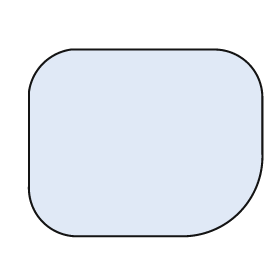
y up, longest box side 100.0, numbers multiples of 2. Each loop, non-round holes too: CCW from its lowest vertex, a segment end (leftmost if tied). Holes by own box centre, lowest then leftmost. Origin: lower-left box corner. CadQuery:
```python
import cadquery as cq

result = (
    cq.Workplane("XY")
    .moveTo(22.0, 0.0)
    .lineTo(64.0, 0.0)
    .threePointArc((90.0, 10.0), (100.0, 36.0))
    .lineTo(100.0, 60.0)
    .threePointArc((94.0, 74.0), (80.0, 80.0))
    .lineTo(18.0, 80.0)
    .threePointArc((6.0, 74.0), (0.0, 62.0))
    .lineTo(0.0, 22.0)
    .threePointArc((6.0, 6.0), (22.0, 0.0))
    .close()
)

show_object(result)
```